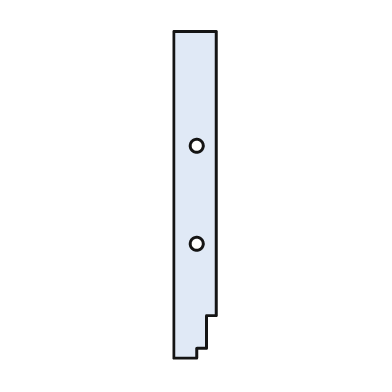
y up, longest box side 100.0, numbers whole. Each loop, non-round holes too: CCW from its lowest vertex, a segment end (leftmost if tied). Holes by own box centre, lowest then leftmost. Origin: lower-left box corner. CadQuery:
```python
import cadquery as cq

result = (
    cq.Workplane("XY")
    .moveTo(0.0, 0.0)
    .lineTo(7.0, 0.0)
    .lineTo(7.0, 3.0)
    .lineTo(10.0, 3.0)
    .lineTo(10.0, 13.0)
    .lineTo(13.0, 13.0)
    .lineTo(13.0, 100.0)
    .lineTo(0.0, 100.0)
    .close()
    .moveTo(7.0, 35.0)
    .circle(2.0)
    .moveTo(7.0, 65.0)
    .circle(2.0)
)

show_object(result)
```